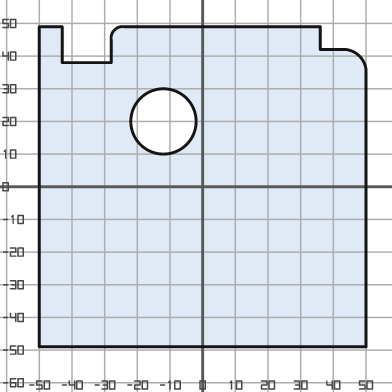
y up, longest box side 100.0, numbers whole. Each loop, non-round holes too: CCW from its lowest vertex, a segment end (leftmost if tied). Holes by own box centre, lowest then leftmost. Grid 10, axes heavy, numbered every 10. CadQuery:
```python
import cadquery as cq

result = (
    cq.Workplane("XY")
    .moveTo(-50.0, -49.0)
    .lineTo(50.0, -49.0)
    .lineTo(50.0, 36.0)
    .threePointArc((48.0, 40.0), (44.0, 42.0))
    .lineTo(36.0, 42.0)
    .lineTo(36.0, 49.0)
    .lineTo(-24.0, 49.0)
    .threePointArc((-27.0, 48.0), (-28.0, 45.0))
    .lineTo(-28.0, 38.0)
    .lineTo(-43.0, 38.0)
    .lineTo(-43.0, 49.0)
    .lineTo(-50.0, 49.0)
    .close()
    .moveTo(-12.0, 20.0)
    .circle(10.0)
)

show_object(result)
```